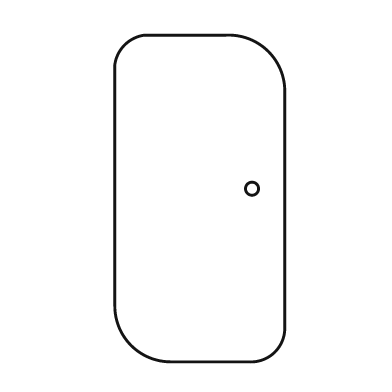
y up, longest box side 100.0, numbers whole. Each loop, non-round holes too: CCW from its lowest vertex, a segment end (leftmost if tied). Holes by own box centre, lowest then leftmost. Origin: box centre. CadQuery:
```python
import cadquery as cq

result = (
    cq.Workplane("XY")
    .moveTo(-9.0, -50.0)
    .lineTo(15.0, -50.0)
    .threePointArc((23.0, -47.0), (26.0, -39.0))
    .lineTo(26.0, 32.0)
    .threePointArc((21.0, 45.0), (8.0, 50.0))
    .lineTo(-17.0, 50.0)
    .threePointArc((-23.0, 47.0), (-26.0, 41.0))
    .lineTo(-26.0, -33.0)
    .threePointArc((-21.0, -45.0), (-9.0, -50.0))
    .close()
    .moveTo(16.0, 3.0)
    .circle(2.0)
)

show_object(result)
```